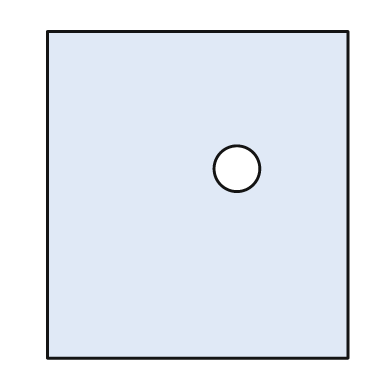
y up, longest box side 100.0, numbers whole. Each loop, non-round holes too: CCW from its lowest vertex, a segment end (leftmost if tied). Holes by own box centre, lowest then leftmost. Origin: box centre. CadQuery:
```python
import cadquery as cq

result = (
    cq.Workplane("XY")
    .moveTo(-46.0, -50.0)
    .lineTo(46.0, -50.0)
    .lineTo(46.0, 50.0)
    .lineTo(-46.0, 50.0)
    .close()
    .moveTo(12.0, 8.0)
    .circle(7.0)
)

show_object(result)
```